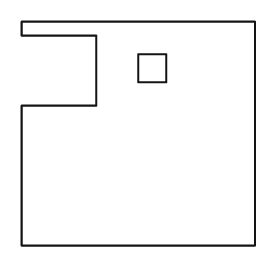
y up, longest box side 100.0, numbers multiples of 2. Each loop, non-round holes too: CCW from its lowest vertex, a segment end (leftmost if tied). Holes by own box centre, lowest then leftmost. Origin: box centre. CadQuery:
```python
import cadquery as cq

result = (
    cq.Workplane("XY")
    .moveTo(-50.0, -48.0)
    .lineTo(50.0, -48.0)
    .lineTo(50.0, 48.0)
    .lineTo(-50.0, 48.0)
    .lineTo(-50.0, 42.0)
    .lineTo(-18.0, 42.0)
    .lineTo(-18.0, 12.0)
    .lineTo(-50.0, 12.0)
    .close()
    .moveTo(0.0, 22.0)
    .lineTo(12.0, 22.0)
    .lineTo(12.0, 34.0)
    .lineTo(0.0, 34.0)
    .close()
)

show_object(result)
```